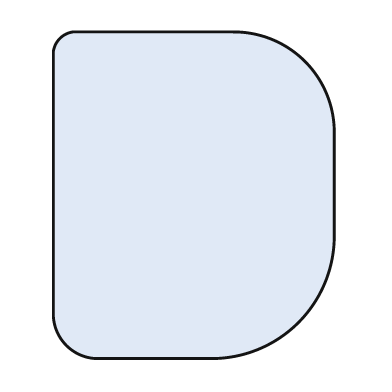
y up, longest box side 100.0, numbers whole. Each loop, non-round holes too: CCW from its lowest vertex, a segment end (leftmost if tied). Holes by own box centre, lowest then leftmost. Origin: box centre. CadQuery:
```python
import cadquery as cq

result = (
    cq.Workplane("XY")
    .moveTo(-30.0, -50.0)
    .lineTo(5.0, -50.0)
    .threePointArc((32.0, -39.0), (43.0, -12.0))
    .lineTo(43.0, 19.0)
    .threePointArc((34.0, 41.0), (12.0, 50.0))
    .lineTo(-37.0, 50.0)
    .threePointArc((-41.0, 48.0), (-43.0, 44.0))
    .lineTo(-43.0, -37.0)
    .threePointArc((-39.0, -46.0), (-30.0, -50.0))
    .close()
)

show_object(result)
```